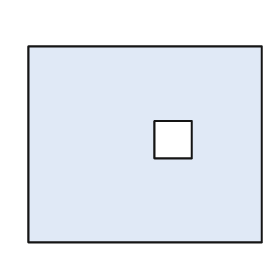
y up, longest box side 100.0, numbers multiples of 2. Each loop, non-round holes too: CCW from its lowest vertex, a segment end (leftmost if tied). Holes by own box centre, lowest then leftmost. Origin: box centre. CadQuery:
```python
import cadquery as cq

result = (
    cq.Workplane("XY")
    .moveTo(-50.0, -42.0)
    .lineTo(50.0, -42.0)
    .lineTo(50.0, 42.0)
    .lineTo(-50.0, 42.0)
    .close()
    .moveTo(4.0, -6.0)
    .lineTo(20.0, -6.0)
    .lineTo(20.0, 10.0)
    .lineTo(4.0, 10.0)
    .close()
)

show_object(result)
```